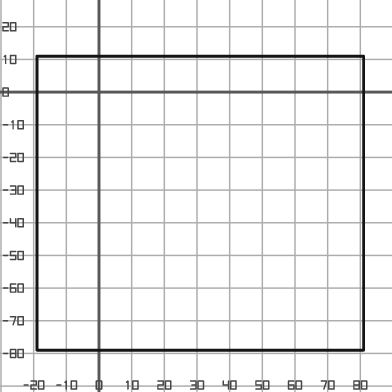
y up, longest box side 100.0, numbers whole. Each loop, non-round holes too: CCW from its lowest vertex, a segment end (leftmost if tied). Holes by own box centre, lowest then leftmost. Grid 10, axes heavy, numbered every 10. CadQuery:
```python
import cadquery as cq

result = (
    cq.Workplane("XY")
    .moveTo(-19.0, -79.0)
    .lineTo(81.0, -79.0)
    .lineTo(81.0, 11.0)
    .lineTo(-19.0, 11.0)
    .close()
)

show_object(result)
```